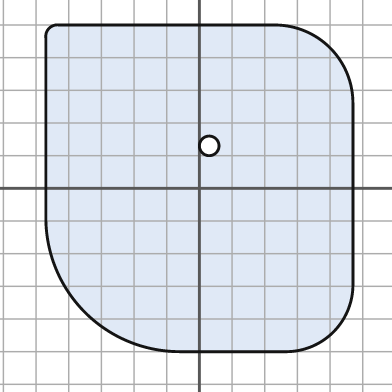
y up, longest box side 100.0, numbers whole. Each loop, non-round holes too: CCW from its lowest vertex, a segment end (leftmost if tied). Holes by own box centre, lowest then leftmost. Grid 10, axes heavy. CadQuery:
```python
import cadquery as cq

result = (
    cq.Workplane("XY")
    .moveTo(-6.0, -50.0)
    .lineTo(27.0, -50.0)
    .threePointArc((41.0, -44.0), (47.0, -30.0))
    .lineTo(47.0, 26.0)
    .threePointArc((40.0, 43.0), (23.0, 50.0))
    .lineTo(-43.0, 50.0)
    .threePointArc((-46.0, 49.0), (-47.0, 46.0))
    .lineTo(-47.0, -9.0)
    .threePointArc((-35.0, -38.0), (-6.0, -50.0))
    .close()
    .moveTo(3.0, 13.0)
    .circle(3.0)
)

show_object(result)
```